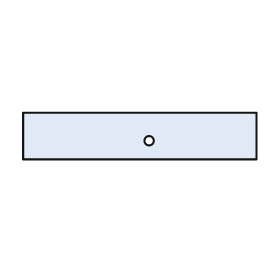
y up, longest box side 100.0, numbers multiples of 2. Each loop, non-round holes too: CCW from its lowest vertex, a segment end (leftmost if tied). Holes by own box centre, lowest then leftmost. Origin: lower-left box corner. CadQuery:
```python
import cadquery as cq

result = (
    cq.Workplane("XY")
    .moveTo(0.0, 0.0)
    .lineTo(100.0, 0.0)
    .lineTo(100.0, 20.0)
    .lineTo(0.0, 20.0)
    .close()
    .moveTo(54.0, 8.0)
    .circle(2.0)
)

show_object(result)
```